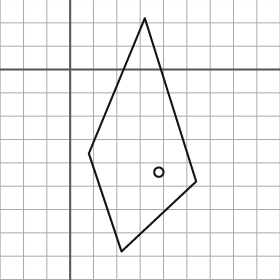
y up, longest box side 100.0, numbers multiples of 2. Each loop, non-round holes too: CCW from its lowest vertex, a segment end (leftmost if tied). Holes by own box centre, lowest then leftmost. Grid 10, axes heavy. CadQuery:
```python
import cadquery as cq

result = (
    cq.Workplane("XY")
    .moveTo(22.0, -78.0)
    .lineTo(54.0, -48.0)
    .lineTo(32.0, 22.0)
    .lineTo(8.0, -36.0)
    .close()
    .moveTo(38.0, -44.0)
    .circle(2.0)
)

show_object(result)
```